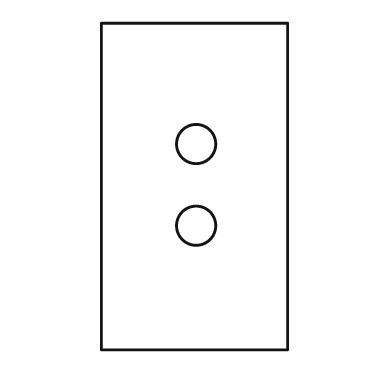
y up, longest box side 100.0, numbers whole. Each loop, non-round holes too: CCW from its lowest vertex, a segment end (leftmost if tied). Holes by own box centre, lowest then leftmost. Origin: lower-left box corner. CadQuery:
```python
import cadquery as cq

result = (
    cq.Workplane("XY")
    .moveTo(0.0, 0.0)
    .lineTo(57.0, 0.0)
    .lineTo(57.0, 100.0)
    .lineTo(0.0, 100.0)
    .close()
    .moveTo(29.0, 38.0)
    .circle(6.0)
    .moveTo(29.0, 63.0)
    .circle(6.0)
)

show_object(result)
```